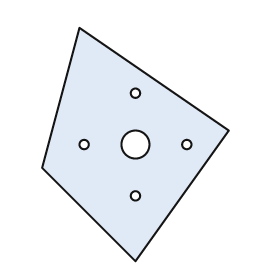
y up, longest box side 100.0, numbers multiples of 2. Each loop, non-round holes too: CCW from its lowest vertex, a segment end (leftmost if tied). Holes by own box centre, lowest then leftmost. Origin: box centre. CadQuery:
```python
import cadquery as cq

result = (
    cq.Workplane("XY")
    .moveTo(0.0, -50.0)
    .lineTo(40.0, 6.0)
    .lineTo(-24.0, 50.0)
    .lineTo(-40.0, -10.0)
    .close()
    .moveTo(0.0, -22.0)
    .circle(2.0)
    .moveTo(-22.0, 0.0)
    .circle(2.0)
    .moveTo(0.0, 0.0)
    .circle(6.0)
    .moveTo(22.0, 0.0)
    .circle(2.0)
    .moveTo(0.0, 22.0)
    .circle(2.0)
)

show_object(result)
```